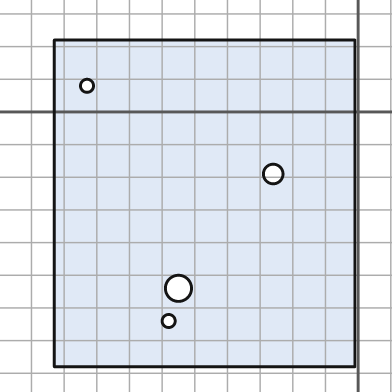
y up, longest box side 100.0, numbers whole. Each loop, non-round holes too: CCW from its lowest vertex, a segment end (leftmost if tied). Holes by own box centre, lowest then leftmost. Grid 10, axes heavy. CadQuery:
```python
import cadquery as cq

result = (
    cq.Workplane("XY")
    .moveTo(-93.0, -78.0)
    .lineTo(-1.0, -78.0)
    .lineTo(-1.0, 22.0)
    .lineTo(-93.0, 22.0)
    .close()
    .moveTo(-58.0, -64.0)
    .circle(2.0)
    .moveTo(-55.0, -54.0)
    .circle(4.0)
    .moveTo(-26.0, -19.0)
    .circle(3.0)
    .moveTo(-83.0, 8.0)
    .circle(2.0)
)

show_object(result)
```